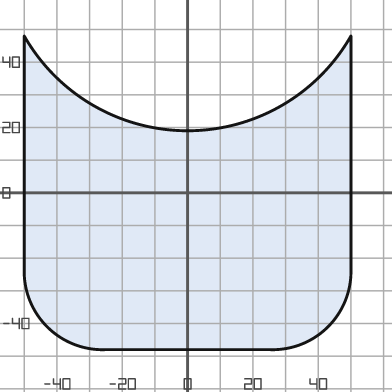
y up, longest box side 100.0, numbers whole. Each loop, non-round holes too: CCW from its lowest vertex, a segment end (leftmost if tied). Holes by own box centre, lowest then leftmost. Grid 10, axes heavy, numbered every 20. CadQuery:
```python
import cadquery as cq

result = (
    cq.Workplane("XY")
    .moveTo(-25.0, -48.0)
    .lineTo(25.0, -48.0)
    .threePointArc((43.0, -41.0), (50.0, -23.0))
    .lineTo(50.0, 48.0)
    .threePointArc((0.0, 19.0), (-50.0, 48.0))
    .lineTo(-50.0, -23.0)
    .threePointArc((-43.0, -41.0), (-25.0, -48.0))
    .close()
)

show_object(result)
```